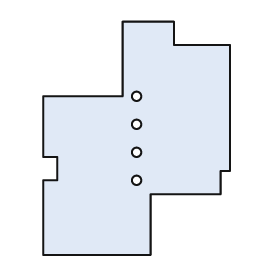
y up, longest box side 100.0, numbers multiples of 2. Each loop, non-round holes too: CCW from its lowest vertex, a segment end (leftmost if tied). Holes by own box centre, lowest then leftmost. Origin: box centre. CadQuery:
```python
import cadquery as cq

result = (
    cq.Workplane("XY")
    .moveTo(-40.0, -50.0)
    .lineTo(6.0, -50.0)
    .lineTo(6.0, -24.0)
    .lineTo(36.0, -24.0)
    .lineTo(36.0, -14.0)
    .lineTo(40.0, -14.0)
    .lineTo(40.0, 40.0)
    .lineTo(16.0, 40.0)
    .lineTo(16.0, 50.0)
    .lineTo(-6.0, 50.0)
    .lineTo(-6.0, 18.0)
    .lineTo(-40.0, 18.0)
    .lineTo(-40.0, -8.0)
    .lineTo(-34.0, -8.0)
    .lineTo(-34.0, -18.0)
    .lineTo(-40.0, -18.0)
    .close()
    .moveTo(0.0, -18.0)
    .circle(2.0)
    .moveTo(0.0, -6.0)
    .circle(2.0)
    .moveTo(0.0, 6.0)
    .circle(2.0)
    .moveTo(0.0, 18.0)
    .circle(2.0)
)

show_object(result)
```